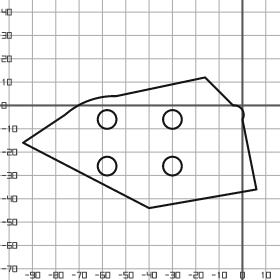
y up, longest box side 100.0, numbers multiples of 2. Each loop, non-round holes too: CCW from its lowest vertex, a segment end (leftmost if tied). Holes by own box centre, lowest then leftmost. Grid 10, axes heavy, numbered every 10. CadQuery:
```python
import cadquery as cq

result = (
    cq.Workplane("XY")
    .moveTo(-40.0, -44.0)
    .lineTo(6.0, -36.0)
    .lineTo(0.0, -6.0)
    .threePointArc((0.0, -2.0), (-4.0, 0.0))
    .lineTo(-16.0, 12.0)
    .lineTo(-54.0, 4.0)
    .threePointArc((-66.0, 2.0), (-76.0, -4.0))
    .lineTo(-94.0, -16.0)
    .close()
    .moveTo(-58.0, -26.0)
    .circle(4.0)
    .moveTo(-30.0, -26.0)
    .circle(4.0)
    .moveTo(-58.0, -6.0)
    .circle(4.0)
    .moveTo(-30.0, -6.0)
    .circle(4.0)
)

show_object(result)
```